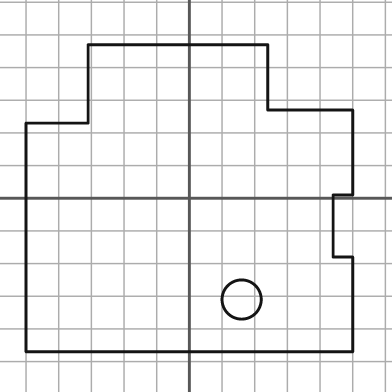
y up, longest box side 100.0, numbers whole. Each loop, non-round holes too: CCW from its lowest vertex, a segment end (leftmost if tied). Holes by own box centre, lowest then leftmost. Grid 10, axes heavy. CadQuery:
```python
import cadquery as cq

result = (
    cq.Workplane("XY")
    .moveTo(-50.0, -47.0)
    .lineTo(50.0, -47.0)
    .lineTo(50.0, -18.0)
    .lineTo(44.0, -18.0)
    .lineTo(44.0, 1.0)
    .lineTo(50.0, 1.0)
    .lineTo(50.0, 27.0)
    .lineTo(24.0, 27.0)
    .lineTo(24.0, 47.0)
    .lineTo(-31.0, 47.0)
    .lineTo(-31.0, 23.0)
    .lineTo(-50.0, 23.0)
    .close()
    .moveTo(16.0, -31.0)
    .circle(6.0)
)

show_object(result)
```